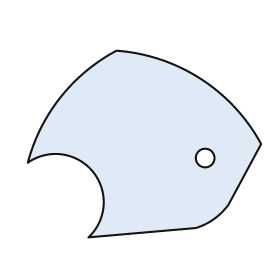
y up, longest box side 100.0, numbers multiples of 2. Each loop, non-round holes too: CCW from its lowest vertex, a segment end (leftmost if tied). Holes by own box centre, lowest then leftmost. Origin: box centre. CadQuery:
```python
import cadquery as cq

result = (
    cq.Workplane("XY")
    .moveTo(-24.0, -40.0)
    .lineTo(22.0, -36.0)
    .threePointArc((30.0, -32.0), (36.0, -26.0))
    .lineTo(50.0, 0.0)
    .threePointArc((24.0, 28.0), (-12.0, 40.0))
    .threePointArc((-36.0, 20.0), (-50.0, -8.0))
    .threePointArc((-22.0, -12.0), (-24.0, -40.0))
    .close()
    .moveTo(26.0, -6.0)
    .circle(4.0)
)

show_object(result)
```